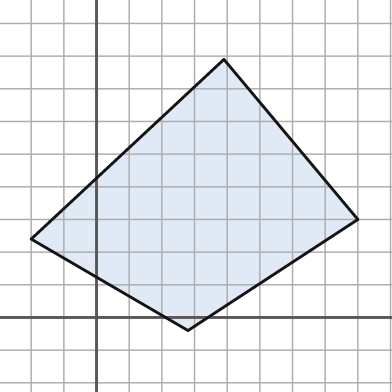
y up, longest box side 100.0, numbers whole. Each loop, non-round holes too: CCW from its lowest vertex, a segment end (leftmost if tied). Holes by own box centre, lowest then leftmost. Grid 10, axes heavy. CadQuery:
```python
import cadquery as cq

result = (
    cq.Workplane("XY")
    .moveTo(28.0, -4.0)
    .lineTo(80.0, 30.0)
    .lineTo(39.0, 79.0)
    .lineTo(-20.0, 24.0)
    .close()
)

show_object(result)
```